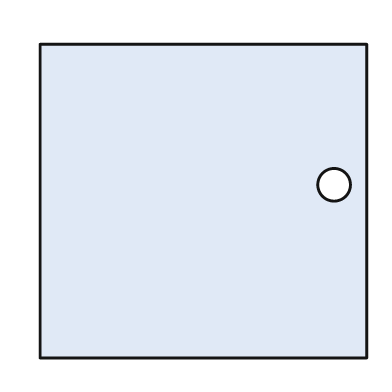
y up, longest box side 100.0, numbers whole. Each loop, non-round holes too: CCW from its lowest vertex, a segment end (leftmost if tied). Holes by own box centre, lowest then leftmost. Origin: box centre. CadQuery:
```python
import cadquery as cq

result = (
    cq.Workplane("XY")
    .moveTo(-50.0, -48.0)
    .lineTo(50.0, -48.0)
    .lineTo(50.0, 48.0)
    .lineTo(-50.0, 48.0)
    .close()
    .moveTo(40.0, 5.0)
    .circle(5.0)
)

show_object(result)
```